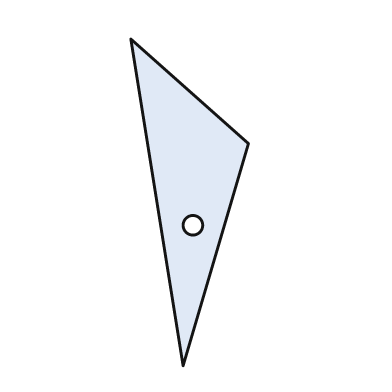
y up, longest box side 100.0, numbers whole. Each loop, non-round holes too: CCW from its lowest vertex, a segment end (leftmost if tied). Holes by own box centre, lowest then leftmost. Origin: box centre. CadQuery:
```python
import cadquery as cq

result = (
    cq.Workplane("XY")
    .moveTo(-2.0, -50.0)
    .lineTo(18.0, 18.0)
    .lineTo(-18.0, 50.0)
    .close()
    .moveTo(1.0, -7.0)
    .circle(3.0)
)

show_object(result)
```